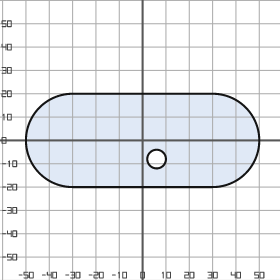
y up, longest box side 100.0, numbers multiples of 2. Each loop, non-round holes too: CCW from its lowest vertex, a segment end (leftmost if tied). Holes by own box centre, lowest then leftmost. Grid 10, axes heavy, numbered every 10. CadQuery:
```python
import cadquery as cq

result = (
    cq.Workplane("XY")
    .moveTo(-30.0, -20.0)
    .lineTo(30.0, -20.0)
    .threePointArc((50.0, 0.0), (30.0, 20.0))
    .lineTo(-30.0, 20.0)
    .threePointArc((-50.0, 0.0), (-30.0, -20.0))
    .close()
    .moveTo(6.0, -8.0)
    .circle(4.0)
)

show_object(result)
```